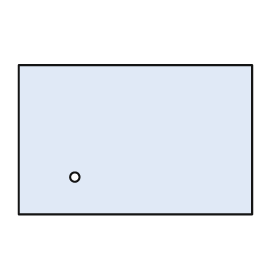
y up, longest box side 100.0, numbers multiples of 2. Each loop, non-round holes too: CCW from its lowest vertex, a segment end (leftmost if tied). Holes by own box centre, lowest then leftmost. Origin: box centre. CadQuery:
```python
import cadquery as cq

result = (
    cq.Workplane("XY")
    .moveTo(-50.0, -32.0)
    .lineTo(50.0, -32.0)
    .lineTo(50.0, 32.0)
    .lineTo(-50.0, 32.0)
    .close()
    .moveTo(-26.0, -16.0)
    .circle(2.0)
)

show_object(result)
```